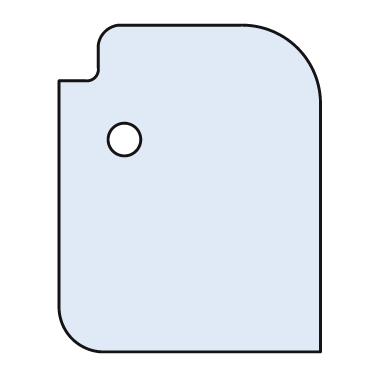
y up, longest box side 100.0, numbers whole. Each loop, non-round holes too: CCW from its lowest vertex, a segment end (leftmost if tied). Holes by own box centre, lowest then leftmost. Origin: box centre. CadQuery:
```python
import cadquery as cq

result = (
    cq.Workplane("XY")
    .moveTo(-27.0, -50.0)
    .lineTo(40.0, -50.0)
    .lineTo(40.0, 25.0)
    .threePointArc((33.0, 43.0), (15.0, 50.0))
    .lineTo(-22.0, 50.0)
    .threePointArc((-26.0, 48.0), (-28.0, 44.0))
    .lineTo(-28.0, 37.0)
    .threePointArc((-29.0, 34.0), (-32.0, 33.0))
    .lineTo(-40.0, 33.0)
    .lineTo(-40.0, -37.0)
    .threePointArc((-36.0, -46.0), (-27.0, -50.0))
    .close()
    .moveTo(-20.0, 15.0)
    .circle(5.0)
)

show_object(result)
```